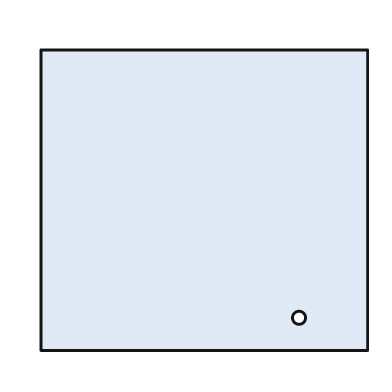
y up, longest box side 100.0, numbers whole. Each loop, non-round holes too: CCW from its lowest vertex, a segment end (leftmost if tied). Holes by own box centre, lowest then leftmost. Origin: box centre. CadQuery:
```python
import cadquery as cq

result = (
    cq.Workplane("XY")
    .moveTo(-50.0, -46.0)
    .lineTo(50.0, -46.0)
    .lineTo(50.0, 46.0)
    .lineTo(-50.0, 46.0)
    .close()
    .moveTo(29.0, -36.0)
    .circle(2.0)
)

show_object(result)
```